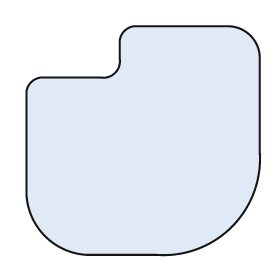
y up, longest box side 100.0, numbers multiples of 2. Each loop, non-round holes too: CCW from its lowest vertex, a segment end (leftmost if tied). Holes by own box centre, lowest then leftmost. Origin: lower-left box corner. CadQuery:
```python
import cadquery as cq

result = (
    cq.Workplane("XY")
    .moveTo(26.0, 0.0)
    .lineTo(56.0, 0.0)
    .threePointArc((88.0, 12.0), (100.0, 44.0))
    .lineTo(100.0, 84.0)
    .threePointArc((96.0, 94.0), (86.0, 98.0))
    .lineTo(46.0, 98.0)
    .threePointArc((42.0, 96.0), (40.0, 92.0))
    .lineTo(40.0, 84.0)
    .threePointArc((38.0, 78.0), (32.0, 76.0))
    .lineTo(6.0, 76.0)
    .threePointArc((2.0, 74.0), (0.0, 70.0))
    .lineTo(0.0, 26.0)
    .threePointArc((8.0, 8.0), (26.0, 0.0))
    .close()
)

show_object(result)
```